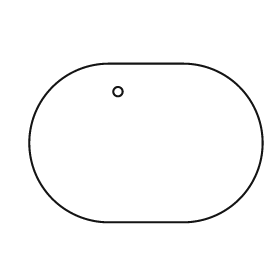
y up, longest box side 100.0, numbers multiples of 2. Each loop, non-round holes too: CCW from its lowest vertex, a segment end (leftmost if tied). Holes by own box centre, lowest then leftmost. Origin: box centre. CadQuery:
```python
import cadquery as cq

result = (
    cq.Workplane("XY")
    .moveTo(-16.0, -34.0)
    .lineTo(16.0, -34.0)
    .threePointArc((50.0, 0.0), (16.0, 34.0))
    .lineTo(-16.0, 34.0)
    .threePointArc((-50.0, 0.0), (-16.0, -34.0))
    .close()
    .moveTo(-12.0, 22.0)
    .circle(2.0)
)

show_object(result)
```